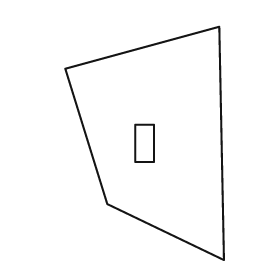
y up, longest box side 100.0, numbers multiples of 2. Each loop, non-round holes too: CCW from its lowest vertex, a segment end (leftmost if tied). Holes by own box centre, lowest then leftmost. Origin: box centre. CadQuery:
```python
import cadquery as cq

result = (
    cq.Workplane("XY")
    .moveTo(34.0, -50.0)
    .lineTo(32.0, 50.0)
    .lineTo(-34.0, 32.0)
    .lineTo(-16.0, -26.0)
    .close()
    .moveTo(-4.0, -8.0)
    .lineTo(4.0, -8.0)
    .lineTo(4.0, 8.0)
    .lineTo(-4.0, 8.0)
    .close()
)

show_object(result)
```